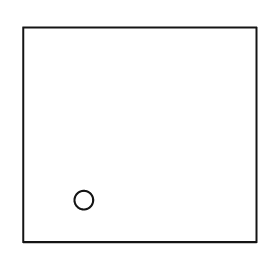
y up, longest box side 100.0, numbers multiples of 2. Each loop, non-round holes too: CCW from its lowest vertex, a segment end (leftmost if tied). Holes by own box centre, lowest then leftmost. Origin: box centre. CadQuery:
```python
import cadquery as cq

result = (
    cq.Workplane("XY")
    .moveTo(-50.0, -46.0)
    .lineTo(50.0, -46.0)
    .lineTo(50.0, 46.0)
    .lineTo(-50.0, 46.0)
    .close()
    .moveTo(-24.0, -28.0)
    .circle(4.0)
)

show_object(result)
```